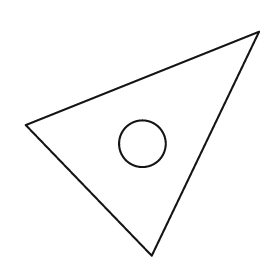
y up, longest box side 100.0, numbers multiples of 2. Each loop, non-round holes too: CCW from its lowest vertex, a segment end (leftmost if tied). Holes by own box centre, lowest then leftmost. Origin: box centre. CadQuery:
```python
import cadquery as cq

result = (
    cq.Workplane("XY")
    .moveTo(4.0, -48.0)
    .lineTo(50.0, 48.0)
    .lineTo(-50.0, 8.0)
    .close()
    .moveTo(0.0, 0.0)
    .circle(10.0)
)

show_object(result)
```